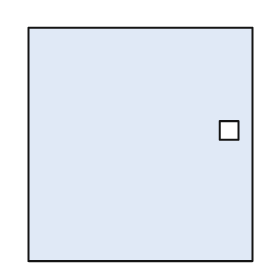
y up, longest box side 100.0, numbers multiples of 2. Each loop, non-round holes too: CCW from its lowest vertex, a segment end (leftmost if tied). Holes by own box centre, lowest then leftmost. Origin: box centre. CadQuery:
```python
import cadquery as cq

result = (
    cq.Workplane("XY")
    .moveTo(-48.0, -50.0)
    .lineTo(48.0, -50.0)
    .lineTo(48.0, 50.0)
    .lineTo(-48.0, 50.0)
    .close()
    .moveTo(34.0, 2.0)
    .lineTo(42.0, 2.0)
    .lineTo(42.0, 10.0)
    .lineTo(34.0, 10.0)
    .close()
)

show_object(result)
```